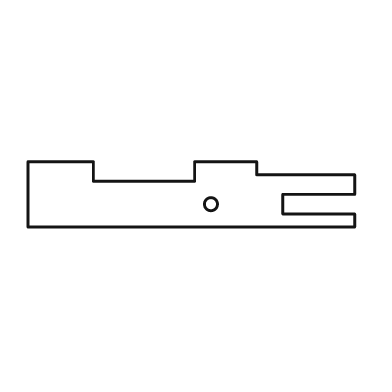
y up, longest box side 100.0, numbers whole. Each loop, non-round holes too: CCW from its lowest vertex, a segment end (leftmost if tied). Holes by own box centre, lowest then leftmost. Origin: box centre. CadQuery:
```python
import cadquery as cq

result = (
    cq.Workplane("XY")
    .moveTo(-50.0, -10.0)
    .lineTo(50.0, -10.0)
    .lineTo(50.0, -6.0)
    .lineTo(28.0, -6.0)
    .lineTo(28.0, 0.0)
    .lineTo(50.0, 0.0)
    .lineTo(50.0, 6.0)
    .lineTo(20.0, 6.0)
    .lineTo(20.0, 10.0)
    .lineTo(1.0, 10.0)
    .lineTo(1.0, 4.0)
    .lineTo(-30.0, 4.0)
    .lineTo(-30.0, 10.0)
    .lineTo(-50.0, 10.0)
    .close()
    .moveTo(6.0, -3.0)
    .circle(2.0)
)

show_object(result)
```